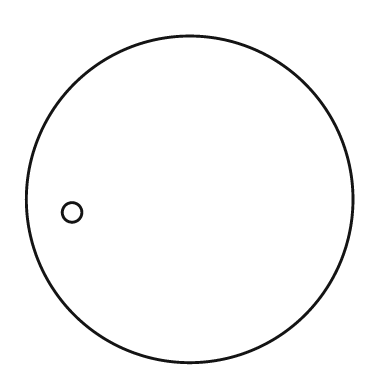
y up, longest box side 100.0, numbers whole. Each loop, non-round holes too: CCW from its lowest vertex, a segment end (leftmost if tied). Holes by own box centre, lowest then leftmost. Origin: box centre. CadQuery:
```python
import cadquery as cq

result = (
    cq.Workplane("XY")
    .moveTo(0.0, 0.0)
    .circle(50.0)
    .moveTo(-36.0, -4.0)
    .circle(3.0)
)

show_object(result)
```